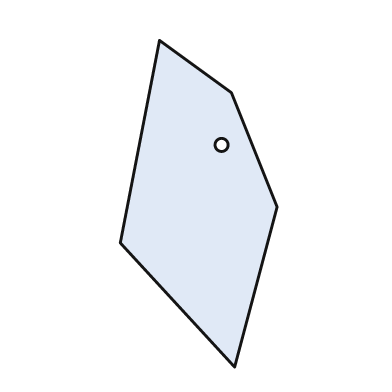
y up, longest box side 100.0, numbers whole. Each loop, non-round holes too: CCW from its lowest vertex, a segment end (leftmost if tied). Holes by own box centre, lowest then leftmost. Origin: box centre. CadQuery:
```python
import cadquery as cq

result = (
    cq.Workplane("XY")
    .moveTo(11.0, -50.0)
    .lineTo(24.0, -1.0)
    .lineTo(10.0, 34.0)
    .lineTo(-12.0, 50.0)
    .lineTo(-24.0, -12.0)
    .close()
    .moveTo(7.0, 18.0)
    .circle(2.0)
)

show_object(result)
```